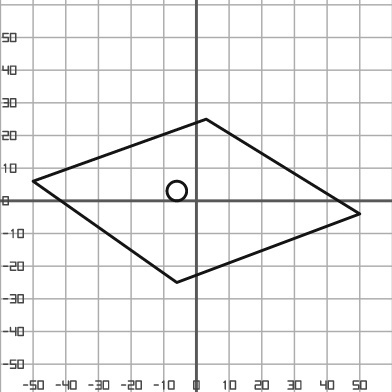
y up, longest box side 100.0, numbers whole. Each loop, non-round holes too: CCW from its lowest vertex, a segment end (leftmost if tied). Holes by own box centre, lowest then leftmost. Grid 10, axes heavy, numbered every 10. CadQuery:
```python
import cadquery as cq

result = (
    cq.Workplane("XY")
    .moveTo(-6.0, -25.0)
    .lineTo(50.0, -4.0)
    .lineTo(3.0, 25.0)
    .lineTo(-50.0, 6.0)
    .close()
    .moveTo(-6.0, 3.0)
    .circle(3.0)
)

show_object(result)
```